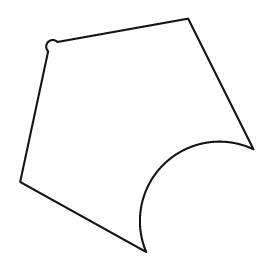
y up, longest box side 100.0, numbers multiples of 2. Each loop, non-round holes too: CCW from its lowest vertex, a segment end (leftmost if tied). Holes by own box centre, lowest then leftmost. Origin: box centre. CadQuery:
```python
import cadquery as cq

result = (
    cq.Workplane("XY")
    .moveTo(4.0, -50.0)
    .threePointArc((12.0, -12.0), (50.0, -6.0))
    .lineTo(22.0, 50.0)
    .lineTo(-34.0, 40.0)
    .threePointArc((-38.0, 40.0), (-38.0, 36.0))
    .lineTo(-50.0, -20.0)
    .close()
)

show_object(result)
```